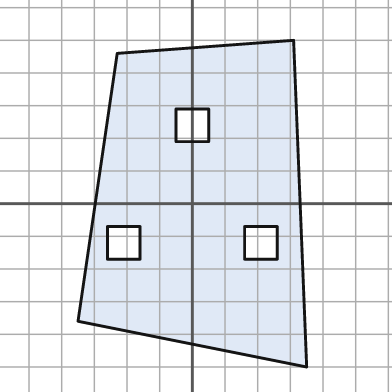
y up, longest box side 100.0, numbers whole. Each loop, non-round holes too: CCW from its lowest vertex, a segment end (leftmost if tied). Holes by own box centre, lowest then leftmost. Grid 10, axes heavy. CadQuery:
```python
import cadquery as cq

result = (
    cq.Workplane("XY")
    .moveTo(35.0, -50.0)
    .lineTo(31.0, 50.0)
    .lineTo(-23.0, 46.0)
    .lineTo(-35.0, -36.0)
    .close()
    .moveTo(-26.0, -17.0)
    .lineTo(-16.0, -17.0)
    .lineTo(-16.0, -7.0)
    .lineTo(-26.0, -7.0)
    .close()
    .moveTo(16.0, -17.0)
    .lineTo(26.0, -17.0)
    .lineTo(26.0, -7.0)
    .lineTo(16.0, -7.0)
    .close()
    .moveTo(-5.0, 19.0)
    .lineTo(5.0, 19.0)
    .lineTo(5.0, 29.0)
    .lineTo(-5.0, 29.0)
    .close()
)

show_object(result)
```